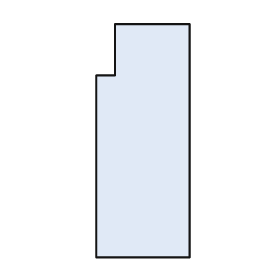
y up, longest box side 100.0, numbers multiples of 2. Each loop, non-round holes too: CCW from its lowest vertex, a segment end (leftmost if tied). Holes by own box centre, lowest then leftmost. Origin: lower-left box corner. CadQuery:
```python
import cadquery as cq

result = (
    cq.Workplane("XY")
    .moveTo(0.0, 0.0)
    .lineTo(40.0, 0.0)
    .lineTo(40.0, 100.0)
    .lineTo(8.0, 100.0)
    .lineTo(8.0, 78.0)
    .lineTo(0.0, 78.0)
    .close()
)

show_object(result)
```